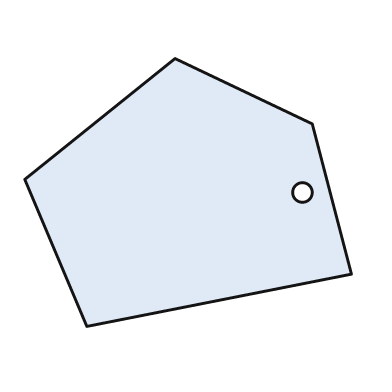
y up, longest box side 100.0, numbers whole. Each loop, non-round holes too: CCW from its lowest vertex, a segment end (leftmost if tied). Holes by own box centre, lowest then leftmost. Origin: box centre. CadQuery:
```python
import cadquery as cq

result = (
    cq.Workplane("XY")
    .moveTo(-31.0, -41.0)
    .lineTo(50.0, -25.0)
    .lineTo(38.0, 21.0)
    .lineTo(-4.0, 41.0)
    .lineTo(-50.0, 4.0)
    .close()
    .moveTo(35.0, 0.0)
    .circle(3.0)
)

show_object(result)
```